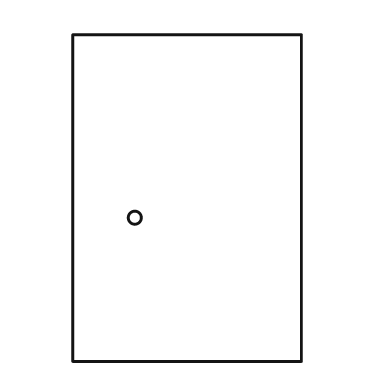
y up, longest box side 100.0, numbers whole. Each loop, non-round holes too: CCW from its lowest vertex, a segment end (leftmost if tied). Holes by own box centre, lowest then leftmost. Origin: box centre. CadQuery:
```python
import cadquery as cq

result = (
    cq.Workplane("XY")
    .moveTo(-35.0, -50.0)
    .lineTo(35.0, -50.0)
    .lineTo(35.0, 50.0)
    .lineTo(-35.0, 50.0)
    .close()
    .moveTo(-16.0, -6.0)
    .circle(2.0)
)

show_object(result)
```